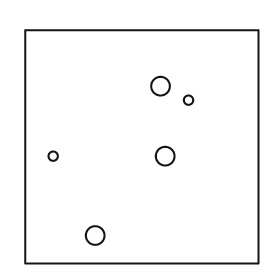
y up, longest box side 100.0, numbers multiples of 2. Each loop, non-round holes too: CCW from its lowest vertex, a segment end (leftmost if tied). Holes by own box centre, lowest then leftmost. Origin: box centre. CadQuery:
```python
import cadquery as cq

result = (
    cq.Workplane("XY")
    .moveTo(-50.0, -50.0)
    .lineTo(50.0, -50.0)
    .lineTo(50.0, 50.0)
    .lineTo(-50.0, 50.0)
    .close()
    .moveTo(-20.0, -38.0)
    .circle(4.0)
    .moveTo(-38.0, -4.0)
    .circle(2.0)
    .moveTo(10.0, -4.0)
    .circle(4.0)
    .moveTo(20.0, 20.0)
    .circle(2.0)
    .moveTo(8.0, 26.0)
    .circle(4.0)
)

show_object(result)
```